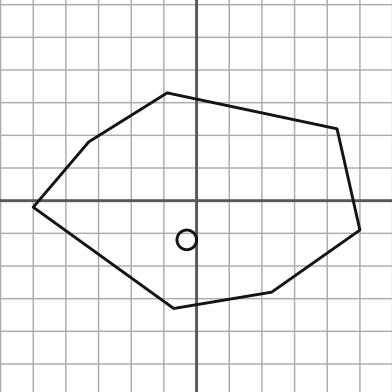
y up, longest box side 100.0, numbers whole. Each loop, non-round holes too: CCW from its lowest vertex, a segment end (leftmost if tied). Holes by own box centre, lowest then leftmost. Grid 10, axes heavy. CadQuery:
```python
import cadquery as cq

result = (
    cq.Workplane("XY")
    .moveTo(-7.0, -33.0)
    .lineTo(23.0, -28.0)
    .lineTo(50.0, -9.0)
    .lineTo(43.0, 22.0)
    .lineTo(-9.0, 33.0)
    .lineTo(-33.0, 18.0)
    .lineTo(-50.0, -2.0)
    .close()
    .moveTo(-3.0, -12.0)
    .circle(3.0)
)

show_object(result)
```